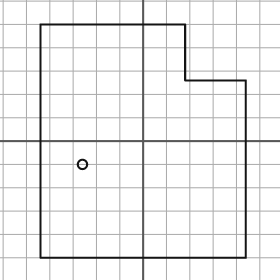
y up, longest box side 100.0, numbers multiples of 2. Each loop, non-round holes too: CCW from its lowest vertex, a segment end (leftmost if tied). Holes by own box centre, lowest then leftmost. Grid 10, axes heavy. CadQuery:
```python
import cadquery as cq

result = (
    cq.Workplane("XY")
    .moveTo(-44.0, -50.0)
    .lineTo(44.0, -50.0)
    .lineTo(44.0, 26.0)
    .lineTo(18.0, 26.0)
    .lineTo(18.0, 50.0)
    .lineTo(-44.0, 50.0)
    .close()
    .moveTo(-26.0, -10.0)
    .circle(2.0)
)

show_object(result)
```